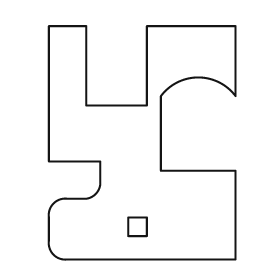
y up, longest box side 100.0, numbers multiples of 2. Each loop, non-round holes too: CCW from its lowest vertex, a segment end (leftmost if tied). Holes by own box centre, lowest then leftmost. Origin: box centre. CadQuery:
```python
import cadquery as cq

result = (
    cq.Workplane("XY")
    .moveTo(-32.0, -50.0)
    .lineTo(40.0, -50.0)
    .lineTo(40.0, -12.0)
    .lineTo(8.0, -12.0)
    .lineTo(8.0, 20.0)
    .threePointArc((24.0, 28.0), (40.0, 20.0))
    .lineTo(40.0, 50.0)
    .lineTo(2.0, 50.0)
    .lineTo(2.0, 16.0)
    .lineTo(-24.0, 16.0)
    .lineTo(-24.0, 50.0)
    .lineTo(-40.0, 50.0)
    .lineTo(-40.0, -8.0)
    .lineTo(-18.0, -8.0)
    .lineTo(-18.0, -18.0)
    .threePointArc((-20.0, -22.0), (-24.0, -24.0))
    .lineTo(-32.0, -24.0)
    .threePointArc((-38.0, -26.0), (-40.0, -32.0))
    .lineTo(-40.0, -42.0)
    .threePointArc((-38.0, -48.0), (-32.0, -50.0))
    .close()
    .moveTo(-6.0, -40.0)
    .lineTo(2.0, -40.0)
    .lineTo(2.0, -32.0)
    .lineTo(-6.0, -32.0)
    .close()
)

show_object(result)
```